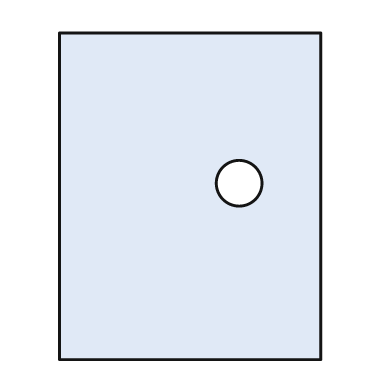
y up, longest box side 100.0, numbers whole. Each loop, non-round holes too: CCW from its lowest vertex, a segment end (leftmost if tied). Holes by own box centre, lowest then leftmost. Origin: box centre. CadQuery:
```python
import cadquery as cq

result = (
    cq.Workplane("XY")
    .moveTo(-40.0, -50.0)
    .lineTo(40.0, -50.0)
    .lineTo(40.0, 50.0)
    .lineTo(-40.0, 50.0)
    .close()
    .moveTo(15.0, 4.0)
    .circle(7.0)
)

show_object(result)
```